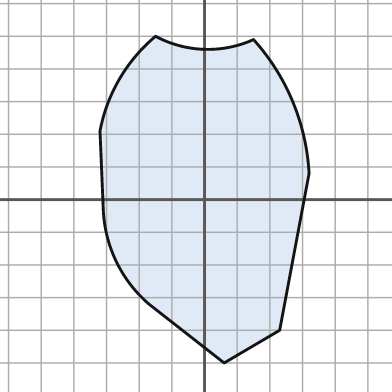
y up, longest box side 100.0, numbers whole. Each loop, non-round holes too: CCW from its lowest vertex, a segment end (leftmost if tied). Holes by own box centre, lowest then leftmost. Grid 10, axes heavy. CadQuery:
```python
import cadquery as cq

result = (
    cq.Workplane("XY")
    .moveTo(6.0, -50.0)
    .lineTo(23.0, -40.0)
    .lineTo(32.0, 8.0)
    .threePointArc((27.0, 30.0), (15.0, 49.0))
    .threePointArc((0.0, 46.0), (-15.0, 50.0))
    .threePointArc((-26.0, 37.0), (-32.0, 21.0))
    .lineTo(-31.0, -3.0)
    .threePointArc((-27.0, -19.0), (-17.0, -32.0))
    .close()
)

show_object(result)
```